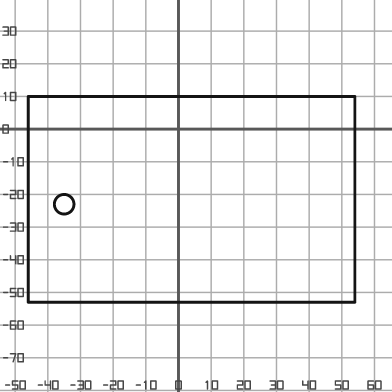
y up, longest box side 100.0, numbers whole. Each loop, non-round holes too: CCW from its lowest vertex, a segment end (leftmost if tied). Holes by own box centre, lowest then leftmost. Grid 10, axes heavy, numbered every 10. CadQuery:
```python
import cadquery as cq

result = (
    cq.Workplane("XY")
    .moveTo(-46.0, -53.0)
    .lineTo(54.0, -53.0)
    .lineTo(54.0, 10.0)
    .lineTo(-46.0, 10.0)
    .close()
    .moveTo(-35.0, -23.0)
    .circle(3.0)
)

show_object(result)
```